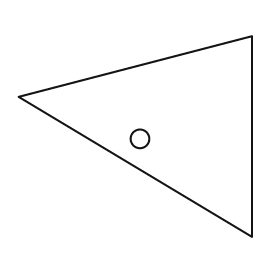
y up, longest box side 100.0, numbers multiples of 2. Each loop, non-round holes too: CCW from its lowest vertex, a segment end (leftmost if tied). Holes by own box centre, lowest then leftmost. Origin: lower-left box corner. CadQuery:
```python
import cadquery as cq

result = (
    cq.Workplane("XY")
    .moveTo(100.0, 0.0)
    .lineTo(100.0, 86.0)
    .lineTo(0.0, 60.0)
    .close()
    .moveTo(52.0, 42.0)
    .circle(4.0)
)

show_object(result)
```